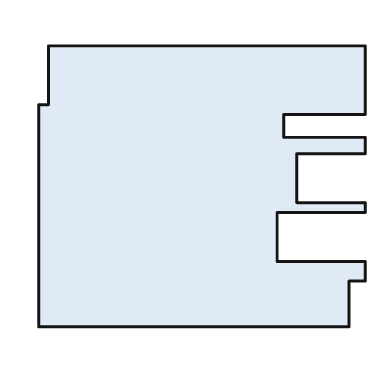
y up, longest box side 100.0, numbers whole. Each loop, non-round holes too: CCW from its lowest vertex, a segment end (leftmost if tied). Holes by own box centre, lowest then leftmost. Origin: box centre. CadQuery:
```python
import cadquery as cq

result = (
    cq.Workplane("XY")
    .moveTo(-50.0, -43.0)
    .lineTo(45.0, -43.0)
    .lineTo(45.0, -29.0)
    .lineTo(50.0, -29.0)
    .lineTo(50.0, -23.0)
    .lineTo(23.0, -23.0)
    .lineTo(23.0, -8.0)
    .lineTo(50.0, -8.0)
    .lineTo(50.0, -5.0)
    .lineTo(29.0, -5.0)
    .lineTo(29.0, 10.0)
    .lineTo(50.0, 10.0)
    .lineTo(50.0, 15.0)
    .lineTo(25.0, 15.0)
    .lineTo(25.0, 22.0)
    .lineTo(50.0, 22.0)
    .lineTo(50.0, 43.0)
    .lineTo(-47.0, 43.0)
    .lineTo(-47.0, 25.0)
    .lineTo(-50.0, 25.0)
    .close()
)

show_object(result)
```